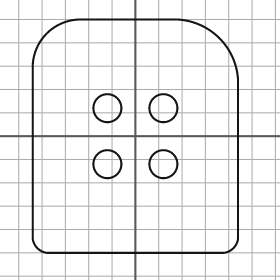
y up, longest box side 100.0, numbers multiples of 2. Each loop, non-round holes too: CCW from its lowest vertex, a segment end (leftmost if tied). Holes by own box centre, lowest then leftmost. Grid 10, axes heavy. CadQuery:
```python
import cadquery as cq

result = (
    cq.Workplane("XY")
    .moveTo(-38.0, -50.0)
    .lineTo(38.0, -50.0)
    .threePointArc((42.0, -48.0), (44.0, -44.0))
    .lineTo(44.0, 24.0)
    .threePointArc((36.0, 42.0), (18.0, 50.0))
    .lineTo(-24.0, 50.0)
    .threePointArc((-38.0, 44.0), (-44.0, 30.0))
    .lineTo(-44.0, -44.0)
    .threePointArc((-42.0, -48.0), (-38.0, -50.0))
    .close()
    .moveTo(-12.0, -12.0)
    .circle(6.0)
    .moveTo(12.0, -12.0)
    .circle(6.0)
    .moveTo(-12.0, 12.0)
    .circle(6.0)
    .moveTo(12.0, 12.0)
    .circle(6.0)
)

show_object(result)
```